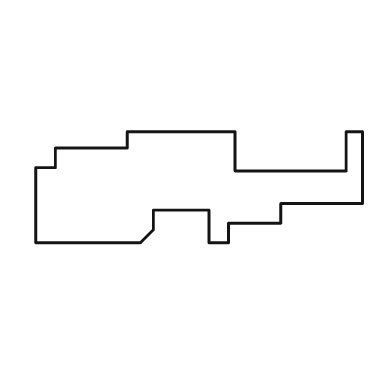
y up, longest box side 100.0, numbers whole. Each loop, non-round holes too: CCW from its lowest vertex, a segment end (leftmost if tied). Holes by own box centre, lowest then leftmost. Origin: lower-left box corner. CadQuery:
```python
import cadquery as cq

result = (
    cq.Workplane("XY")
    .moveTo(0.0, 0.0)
    .lineTo(32.0, 0.0)
    .lineTo(36.0, 4.0)
    .lineTo(36.0, 10.0)
    .lineTo(53.0, 10.0)
    .lineTo(53.0, 0.0)
    .lineTo(59.0, 0.0)
    .lineTo(59.0, 6.0)
    .lineTo(75.0, 6.0)
    .lineTo(75.0, 12.0)
    .lineTo(100.0, 12.0)
    .lineTo(100.0, 34.0)
    .lineTo(95.0, 34.0)
    .lineTo(95.0, 22.0)
    .lineTo(61.0, 22.0)
    .lineTo(61.0, 34.0)
    .lineTo(28.0, 34.0)
    .lineTo(28.0, 29.0)
    .lineTo(6.0, 29.0)
    .lineTo(6.0, 23.0)
    .lineTo(0.0, 23.0)
    .close()
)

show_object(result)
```